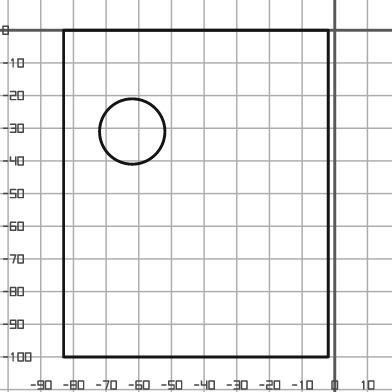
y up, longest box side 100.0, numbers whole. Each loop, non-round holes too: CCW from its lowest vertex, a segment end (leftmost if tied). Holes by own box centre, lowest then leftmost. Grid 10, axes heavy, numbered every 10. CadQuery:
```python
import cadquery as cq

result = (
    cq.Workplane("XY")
    .moveTo(-83.0, -100.0)
    .lineTo(-2.0, -100.0)
    .lineTo(-2.0, 0.0)
    .lineTo(-83.0, 0.0)
    .close()
    .moveTo(-62.0, -31.0)
    .circle(10.0)
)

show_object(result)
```